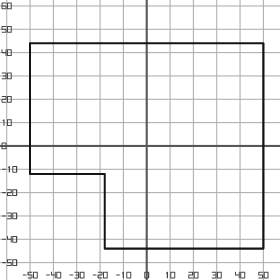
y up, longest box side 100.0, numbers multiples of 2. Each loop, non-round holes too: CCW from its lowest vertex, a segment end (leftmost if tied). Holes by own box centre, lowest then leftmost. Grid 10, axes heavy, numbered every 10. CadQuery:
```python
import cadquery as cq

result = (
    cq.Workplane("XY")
    .moveTo(-18.0, -44.0)
    .lineTo(50.0, -44.0)
    .lineTo(50.0, 44.0)
    .lineTo(-50.0, 44.0)
    .lineTo(-50.0, -12.0)
    .lineTo(-18.0, -12.0)
    .close()
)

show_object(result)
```